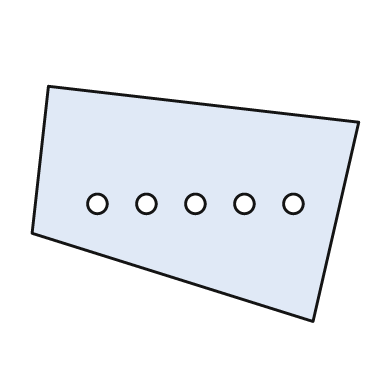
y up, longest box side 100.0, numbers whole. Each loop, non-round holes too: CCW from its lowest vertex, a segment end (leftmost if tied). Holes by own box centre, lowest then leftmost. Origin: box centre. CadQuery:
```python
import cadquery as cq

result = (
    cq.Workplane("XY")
    .moveTo(36.0, -36.0)
    .lineTo(50.0, 25.0)
    .lineTo(-45.0, 36.0)
    .lineTo(-50.0, -9.0)
    .close()
    .moveTo(-30.0, 0.0)
    .circle(3.0)
    .moveTo(-15.0, 0.0)
    .circle(3.0)
    .moveTo(0.0, 0.0)
    .circle(3.0)
    .moveTo(15.0, 0.0)
    .circle(3.0)
    .moveTo(30.0, 0.0)
    .circle(3.0)
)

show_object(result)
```